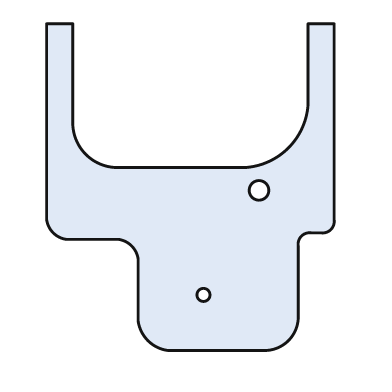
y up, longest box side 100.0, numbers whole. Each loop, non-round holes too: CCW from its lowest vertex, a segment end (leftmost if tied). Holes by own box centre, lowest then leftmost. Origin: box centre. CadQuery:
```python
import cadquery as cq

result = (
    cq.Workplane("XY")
    .moveTo(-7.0, -50.0)
    .lineTo(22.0, -50.0)
    .threePointArc((30.0, -47.0), (33.0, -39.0))
    .lineTo(33.0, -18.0)
    .threePointArc((34.0, -15.0), (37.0, -14.0))
    .lineTo(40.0, -14.0)
    .threePointArc((43.0, -13.0), (44.0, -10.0))
    .lineTo(44.0, 50.0)
    .lineTo(36.0, 50.0)
    .lineTo(36.0, 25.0)
    .threePointArc((30.0, 12.0), (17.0, 6.0))
    .lineTo(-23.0, 6.0)
    .threePointArc((-32.0, 10.0), (-36.0, 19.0))
    .lineTo(-36.0, 50.0)
    .lineTo(-44.0, 50.0)
    .lineTo(-44.0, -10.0)
    .threePointArc((-42.0, -14.0), (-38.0, -16.0))
    .lineTo(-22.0, -16.0)
    .threePointArc((-18.0, -18.0), (-16.0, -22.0))
    .lineTo(-16.0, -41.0)
    .threePointArc((-13.0, -47.0), (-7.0, -50.0))
    .close()
    .moveTo(4.0, -33.0)
    .circle(2.0)
    .moveTo(21.0, -1.0)
    .circle(3.0)
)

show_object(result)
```